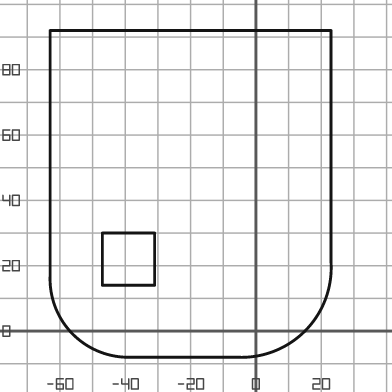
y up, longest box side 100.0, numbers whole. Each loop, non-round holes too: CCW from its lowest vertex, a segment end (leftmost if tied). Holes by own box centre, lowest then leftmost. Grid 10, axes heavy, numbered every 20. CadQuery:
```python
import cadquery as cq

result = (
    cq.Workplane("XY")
    .moveTo(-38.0, -8.0)
    .lineTo(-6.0, -8.0)
    .threePointArc((15.0, 0.0), (23.0, 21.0))
    .lineTo(23.0, 92.0)
    .lineTo(-63.0, 92.0)
    .lineTo(-63.0, 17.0)
    .threePointArc((-56.0, -1.0), (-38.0, -8.0))
    .close()
    .moveTo(-47.0, 14.0)
    .lineTo(-31.0, 14.0)
    .lineTo(-31.0, 30.0)
    .lineTo(-47.0, 30.0)
    .close()
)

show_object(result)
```